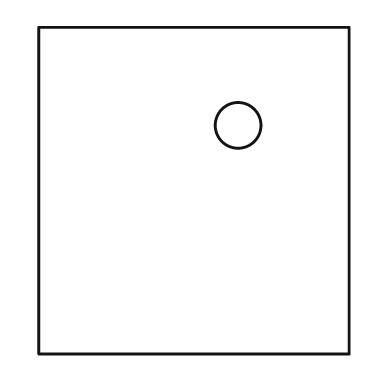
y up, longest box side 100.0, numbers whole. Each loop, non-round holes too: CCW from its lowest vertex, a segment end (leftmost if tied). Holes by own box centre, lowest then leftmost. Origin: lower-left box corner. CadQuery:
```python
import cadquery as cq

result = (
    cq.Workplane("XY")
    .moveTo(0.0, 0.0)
    .lineTo(95.0, 0.0)
    .lineTo(95.0, 100.0)
    .lineTo(0.0, 100.0)
    .close()
    .moveTo(61.0, 70.0)
    .circle(7.0)
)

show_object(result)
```